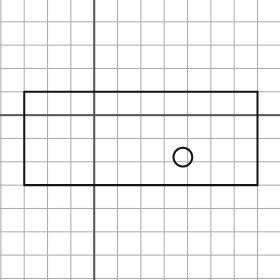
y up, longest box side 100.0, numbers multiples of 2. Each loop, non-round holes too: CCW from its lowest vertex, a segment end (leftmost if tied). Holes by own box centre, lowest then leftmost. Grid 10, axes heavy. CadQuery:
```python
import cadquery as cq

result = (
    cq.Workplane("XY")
    .moveTo(-30.0, -30.0)
    .lineTo(70.0, -30.0)
    .lineTo(70.0, 10.0)
    .lineTo(-30.0, 10.0)
    .close()
    .moveTo(38.0, -18.0)
    .circle(4.0)
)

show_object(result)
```